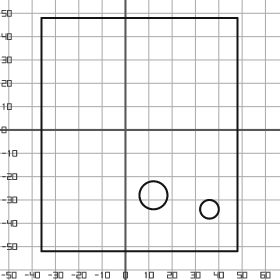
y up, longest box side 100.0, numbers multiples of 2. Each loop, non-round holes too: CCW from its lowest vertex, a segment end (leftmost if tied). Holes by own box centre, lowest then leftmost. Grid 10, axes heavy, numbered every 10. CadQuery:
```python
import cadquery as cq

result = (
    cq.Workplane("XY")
    .moveTo(-36.0, -52.0)
    .lineTo(48.0, -52.0)
    .lineTo(48.0, 48.0)
    .lineTo(-36.0, 48.0)
    .close()
    .moveTo(36.0, -34.0)
    .circle(4.0)
    .moveTo(12.0, -28.0)
    .circle(6.0)
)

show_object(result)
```